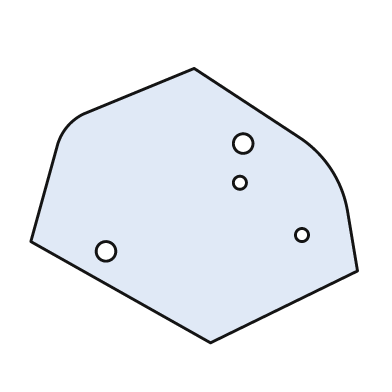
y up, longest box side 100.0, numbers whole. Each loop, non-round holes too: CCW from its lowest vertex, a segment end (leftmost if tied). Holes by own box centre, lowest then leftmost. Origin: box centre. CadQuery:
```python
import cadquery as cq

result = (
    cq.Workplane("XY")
    .moveTo(5.0, -42.0)
    .lineTo(50.0, -20.0)
    .lineTo(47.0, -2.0)
    .threePointArc((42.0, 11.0), (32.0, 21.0))
    .lineTo(0.0, 42.0)
    .lineTo(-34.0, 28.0)
    .threePointArc((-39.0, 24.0), (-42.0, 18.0))
    .lineTo(-50.0, -11.0)
    .close()
    .moveTo(-27.0, -14.0)
    .circle(3.0)
    .moveTo(33.0, -9.0)
    .circle(2.0)
    .moveTo(14.0, 7.0)
    .circle(2.0)
    .moveTo(15.0, 19.0)
    .circle(3.0)
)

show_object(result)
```